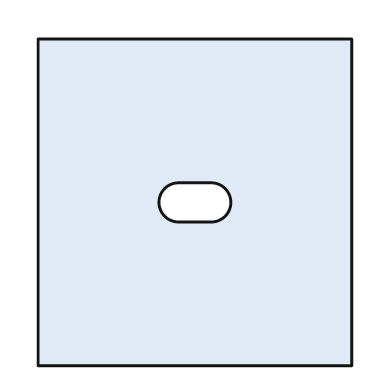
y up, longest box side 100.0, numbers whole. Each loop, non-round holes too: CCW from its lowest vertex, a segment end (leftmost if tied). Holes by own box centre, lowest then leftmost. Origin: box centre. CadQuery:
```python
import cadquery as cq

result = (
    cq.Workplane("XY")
    .moveTo(-48.0, -50.0)
    .lineTo(48.0, -50.0)
    .lineTo(48.0, 50.0)
    .lineTo(-48.0, 50.0)
    .close()
    .moveTo(-5.0, -6.0)
    .lineTo(5.0, -6.0)
    .threePointArc((11.0, 0.0), (5.0, 6.0))
    .lineTo(-5.0, 6.0)
    .threePointArc((-11.0, 0.0), (-5.0, -6.0))
    .close()
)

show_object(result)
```